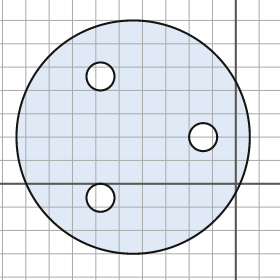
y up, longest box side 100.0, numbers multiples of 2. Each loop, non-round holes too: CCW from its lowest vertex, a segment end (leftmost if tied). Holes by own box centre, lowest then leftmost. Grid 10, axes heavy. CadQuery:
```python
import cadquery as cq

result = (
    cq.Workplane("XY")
    .moveTo(-44.0, 20.0)
    .circle(50.0)
    .moveTo(-58.0, -6.0)
    .circle(6.0)
    .moveTo(-14.0, 20.0)
    .circle(6.0)
    .moveTo(-58.0, 46.0)
    .circle(6.0)
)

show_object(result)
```